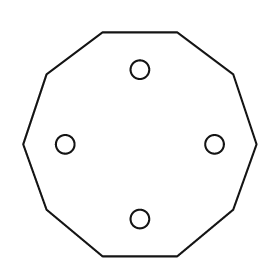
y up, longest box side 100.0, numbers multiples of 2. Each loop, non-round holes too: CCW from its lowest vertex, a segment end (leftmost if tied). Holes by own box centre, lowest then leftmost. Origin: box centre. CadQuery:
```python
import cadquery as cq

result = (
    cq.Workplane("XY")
    .moveTo(-16.0, -48.0)
    .lineTo(16.0, -48.0)
    .lineTo(40.0, -28.0)
    .lineTo(50.0, 0.0)
    .lineTo(40.0, 30.0)
    .lineTo(16.0, 48.0)
    .lineTo(-16.0, 48.0)
    .lineTo(-40.0, 30.0)
    .lineTo(-50.0, 0.0)
    .lineTo(-40.0, -28.0)
    .close()
    .moveTo(0.0, -32.0)
    .circle(4.0)
    .moveTo(-32.0, 0.0)
    .circle(4.0)
    .moveTo(32.0, 0.0)
    .circle(4.0)
    .moveTo(0.0, 32.0)
    .circle(4.0)
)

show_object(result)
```